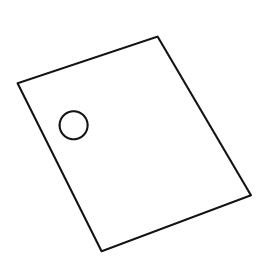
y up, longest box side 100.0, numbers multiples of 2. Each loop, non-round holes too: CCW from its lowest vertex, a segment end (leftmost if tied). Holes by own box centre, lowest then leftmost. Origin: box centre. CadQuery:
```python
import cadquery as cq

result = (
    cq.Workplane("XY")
    .moveTo(-14.0, -46.0)
    .lineTo(50.0, -22.0)
    .lineTo(10.0, 46.0)
    .lineTo(-50.0, 26.0)
    .close()
    .moveTo(-26.0, 8.0)
    .circle(6.0)
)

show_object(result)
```